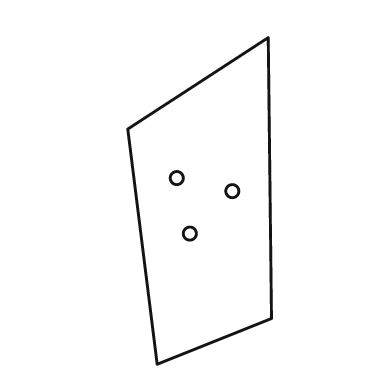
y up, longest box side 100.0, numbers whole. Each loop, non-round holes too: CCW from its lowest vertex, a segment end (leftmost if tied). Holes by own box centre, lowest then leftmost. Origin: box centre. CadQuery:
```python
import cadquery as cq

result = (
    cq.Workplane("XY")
    .moveTo(-13.0, -50.0)
    .lineTo(22.0, -36.0)
    .lineTo(21.0, 50.0)
    .lineTo(-22.0, 22.0)
    .close()
    .moveTo(-3.0, -10.0)
    .circle(2.0)
    .moveTo(10.0, 3.0)
    .circle(2.0)
    .moveTo(-7.0, 7.0)
    .circle(2.0)
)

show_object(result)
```